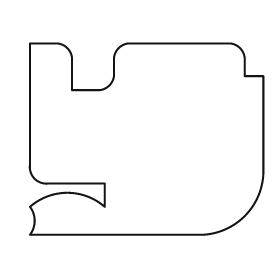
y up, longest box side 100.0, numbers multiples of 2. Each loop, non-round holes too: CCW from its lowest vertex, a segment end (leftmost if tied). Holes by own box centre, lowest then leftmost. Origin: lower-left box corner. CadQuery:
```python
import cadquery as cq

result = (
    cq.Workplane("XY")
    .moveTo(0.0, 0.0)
    .lineTo(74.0, 0.0)
    .threePointArc((92.0, 8.0), (100.0, 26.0))
    .lineTo(100.0, 68.0)
    .lineTo(92.0, 68.0)
    .lineTo(92.0, 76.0)
    .threePointArc((90.0, 80.0), (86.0, 82.0))
    .lineTo(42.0, 82.0)
    .threePointArc((38.0, 80.0), (36.0, 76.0))
    .lineTo(36.0, 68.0)
    .threePointArc((34.0, 64.0), (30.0, 62.0))
    .lineTo(18.0, 62.0)
    .lineTo(18.0, 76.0)
    .threePointArc((16.0, 80.0), (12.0, 82.0))
    .lineTo(0.0, 82.0)
    .lineTo(0.0, 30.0)
    .threePointArc((2.0, 24.0), (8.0, 22.0))
    .lineTo(32.0, 22.0)
    .lineTo(32.0, 12.0)
    .threePointArc((16.0, 18.0), (0.0, 12.0))
    .threePointArc((2.0, 6.0), (0.0, 0.0))
    .close()
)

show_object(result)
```